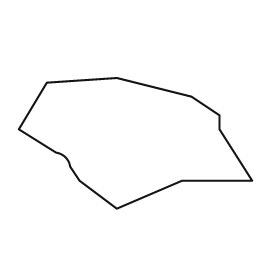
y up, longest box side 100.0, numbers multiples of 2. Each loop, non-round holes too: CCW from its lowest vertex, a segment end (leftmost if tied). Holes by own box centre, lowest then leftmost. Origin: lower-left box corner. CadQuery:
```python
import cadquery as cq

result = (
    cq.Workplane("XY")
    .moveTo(42.0, 0.0)
    .lineTo(70.0, 12.0)
    .lineTo(100.0, 12.0)
    .lineTo(86.0, 34.0)
    .lineTo(86.0, 40.0)
    .lineTo(74.0, 48.0)
    .lineTo(42.0, 56.0)
    .lineTo(12.0, 54.0)
    .lineTo(0.0, 34.0)
    .lineTo(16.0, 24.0)
    .threePointArc((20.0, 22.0), (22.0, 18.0))
    .lineTo(26.0, 12.0)
    .close()
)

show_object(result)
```